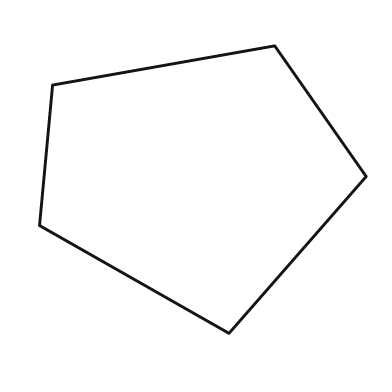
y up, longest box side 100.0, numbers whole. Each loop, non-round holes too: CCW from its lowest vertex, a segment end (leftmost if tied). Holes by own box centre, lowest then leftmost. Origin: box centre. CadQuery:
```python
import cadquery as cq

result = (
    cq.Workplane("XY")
    .moveTo(8.0, -44.0)
    .lineTo(50.0, 4.0)
    .lineTo(22.0, 44.0)
    .lineTo(-46.0, 32.0)
    .lineTo(-50.0, -11.0)
    .close()
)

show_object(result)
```